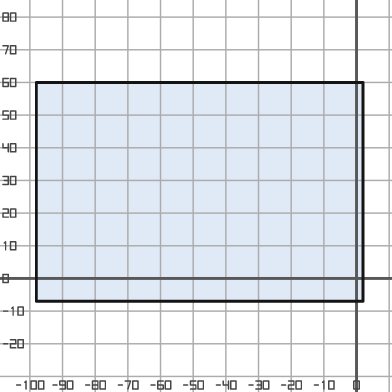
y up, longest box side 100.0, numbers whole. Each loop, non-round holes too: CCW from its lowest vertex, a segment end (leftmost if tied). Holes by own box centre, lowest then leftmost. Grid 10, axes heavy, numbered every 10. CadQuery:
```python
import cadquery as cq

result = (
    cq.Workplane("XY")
    .moveTo(-98.0, -7.0)
    .lineTo(2.0, -7.0)
    .lineTo(2.0, 60.0)
    .lineTo(-98.0, 60.0)
    .close()
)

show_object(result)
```